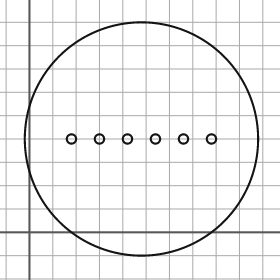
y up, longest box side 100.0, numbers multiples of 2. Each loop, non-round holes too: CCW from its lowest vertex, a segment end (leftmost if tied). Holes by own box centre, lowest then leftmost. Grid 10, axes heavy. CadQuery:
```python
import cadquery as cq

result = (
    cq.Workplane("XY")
    .moveTo(48.0, 40.0)
    .circle(50.0)
    .moveTo(18.0, 40.0)
    .circle(2.0)
    .moveTo(30.0, 40.0)
    .circle(2.0)
    .moveTo(42.0, 40.0)
    .circle(2.0)
    .moveTo(54.0, 40.0)
    .circle(2.0)
    .moveTo(66.0, 40.0)
    .circle(2.0)
    .moveTo(78.0, 40.0)
    .circle(2.0)
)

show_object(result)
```